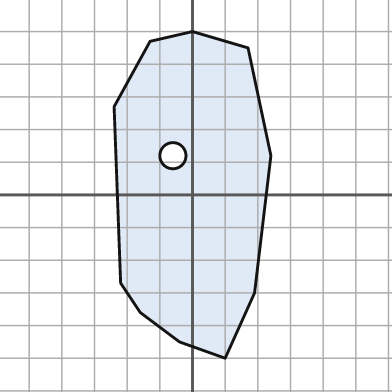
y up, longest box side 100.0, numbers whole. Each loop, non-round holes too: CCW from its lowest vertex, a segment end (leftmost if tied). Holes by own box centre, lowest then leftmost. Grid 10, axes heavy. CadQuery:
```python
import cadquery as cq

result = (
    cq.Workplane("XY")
    .moveTo(10.0, -50.0)
    .lineTo(19.0, -30.0)
    .lineTo(24.0, 12.0)
    .lineTo(17.0, 45.0)
    .lineTo(0.0, 50.0)
    .lineTo(-13.0, 47.0)
    .lineTo(-24.0, 27.0)
    .lineTo(-22.0, -27.0)
    .lineTo(-16.0, -36.0)
    .lineTo(-4.0, -45.0)
    .close()
    .moveTo(-6.0, 12.0)
    .circle(4.0)
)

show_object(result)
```